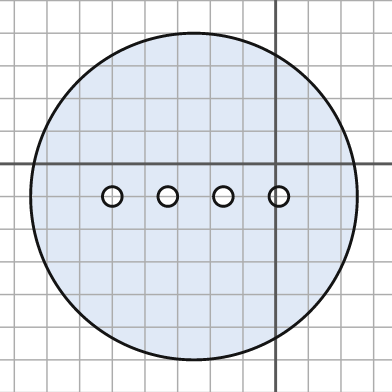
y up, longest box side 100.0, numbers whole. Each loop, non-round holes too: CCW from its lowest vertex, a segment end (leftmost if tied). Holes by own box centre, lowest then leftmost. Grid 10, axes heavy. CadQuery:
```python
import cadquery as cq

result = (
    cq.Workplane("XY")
    .moveTo(-25.0, -10.0)
    .circle(50.0)
    .moveTo(-50.0, -10.0)
    .circle(3.0)
    .moveTo(-33.0, -10.0)
    .circle(3.0)
    .moveTo(-16.0, -10.0)
    .circle(3.0)
    .moveTo(1.0, -10.0)
    .circle(3.0)
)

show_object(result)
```